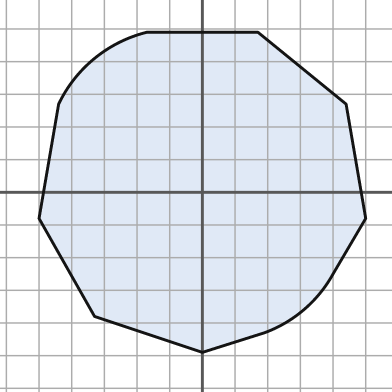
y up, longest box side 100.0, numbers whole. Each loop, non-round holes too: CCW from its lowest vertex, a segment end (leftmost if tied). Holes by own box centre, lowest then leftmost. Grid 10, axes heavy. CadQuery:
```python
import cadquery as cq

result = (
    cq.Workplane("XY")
    .moveTo(0.0, -49.0)
    .lineTo(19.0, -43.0)
    .threePointArc((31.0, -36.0), (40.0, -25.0))
    .lineTo(50.0, -8.0)
    .lineTo(44.0, 27.0)
    .lineTo(17.0, 49.0)
    .lineTo(-17.0, 49.0)
    .threePointArc((-33.0, 41.0), (-44.0, 27.0))
    .lineTo(-50.0, -8.0)
    .lineTo(-33.0, -38.0)
    .close()
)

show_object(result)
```